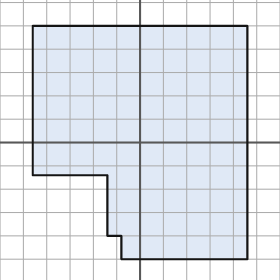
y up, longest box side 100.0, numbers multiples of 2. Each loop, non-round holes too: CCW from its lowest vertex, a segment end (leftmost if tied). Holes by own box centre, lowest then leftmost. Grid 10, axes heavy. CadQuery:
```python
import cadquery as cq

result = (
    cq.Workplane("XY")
    .moveTo(-8.0, -50.0)
    .lineTo(46.0, -50.0)
    .lineTo(46.0, 50.0)
    .lineTo(-46.0, 50.0)
    .lineTo(-46.0, -14.0)
    .lineTo(-14.0, -14.0)
    .lineTo(-14.0, -40.0)
    .lineTo(-8.0, -40.0)
    .close()
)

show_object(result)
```